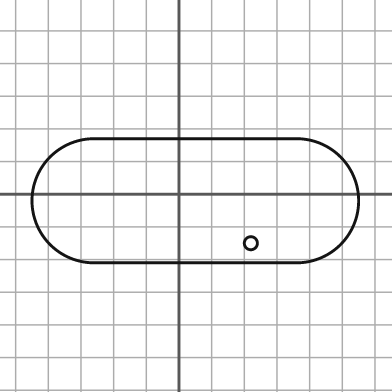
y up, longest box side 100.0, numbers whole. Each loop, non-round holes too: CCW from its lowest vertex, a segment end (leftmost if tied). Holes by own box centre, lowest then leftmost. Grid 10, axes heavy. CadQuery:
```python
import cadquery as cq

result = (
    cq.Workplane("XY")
    .moveTo(-26.0, -21.0)
    .lineTo(36.0, -21.0)
    .threePointArc((55.0, -2.0), (36.0, 17.0))
    .lineTo(-26.0, 17.0)
    .threePointArc((-45.0, -2.0), (-26.0, -21.0))
    .close()
    .moveTo(22.0, -15.0)
    .circle(2.0)
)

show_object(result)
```